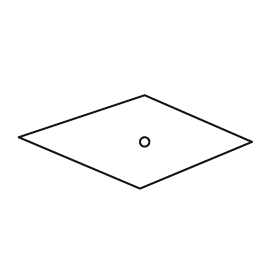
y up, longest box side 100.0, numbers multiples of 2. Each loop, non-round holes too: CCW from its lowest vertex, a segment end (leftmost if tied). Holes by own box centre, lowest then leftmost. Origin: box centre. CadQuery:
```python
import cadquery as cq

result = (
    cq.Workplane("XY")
    .moveTo(2.0, -20.0)
    .lineTo(50.0, 0.0)
    .lineTo(4.0, 20.0)
    .lineTo(-50.0, 2.0)
    .close()
    .moveTo(4.0, 0.0)
    .circle(2.0)
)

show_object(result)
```